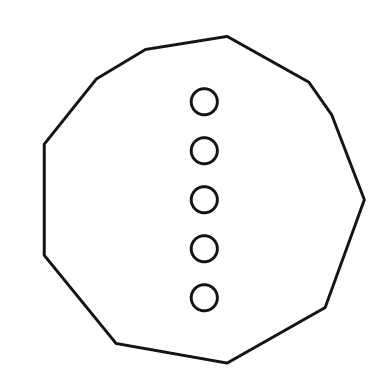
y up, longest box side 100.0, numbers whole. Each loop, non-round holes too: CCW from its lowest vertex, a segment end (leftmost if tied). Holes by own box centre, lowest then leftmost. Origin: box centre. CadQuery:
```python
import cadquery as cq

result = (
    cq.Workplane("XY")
    .moveTo(7.0, -50.0)
    .lineTo(37.0, -33.0)
    .lineTo(49.0, 0.0)
    .lineTo(39.0, 26.0)
    .lineTo(32.0, 36.0)
    .lineTo(7.0, 50.0)
    .lineTo(-18.0, 46.0)
    .lineTo(-33.0, 37.0)
    .lineTo(-49.0, 17.0)
    .lineTo(-49.0, -17.0)
    .lineTo(-27.0, -44.0)
    .close()
    .moveTo(0.0, -30.0)
    .circle(4.0)
    .moveTo(0.0, -15.0)
    .circle(4.0)
    .moveTo(0.0, 0.0)
    .circle(4.0)
    .moveTo(0.0, 15.0)
    .circle(4.0)
    .moveTo(0.0, 30.0)
    .circle(4.0)
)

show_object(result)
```